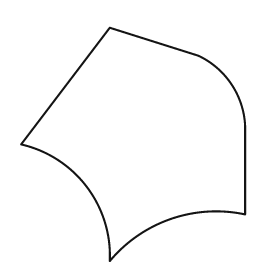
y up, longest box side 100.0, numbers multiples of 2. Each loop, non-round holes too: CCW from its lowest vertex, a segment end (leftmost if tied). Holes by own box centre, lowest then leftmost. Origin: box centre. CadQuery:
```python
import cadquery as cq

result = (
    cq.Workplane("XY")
    .moveTo(-10.0, -50.0)
    .threePointArc((16.0, -32.0), (48.0, -30.0))
    .lineTo(48.0, 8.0)
    .threePointArc((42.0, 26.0), (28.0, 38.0))
    .lineTo(-10.0, 50.0)
    .lineTo(-48.0, 0.0)
    .threePointArc((-20.0, -18.0), (-10.0, -50.0))
    .close()
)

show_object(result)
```